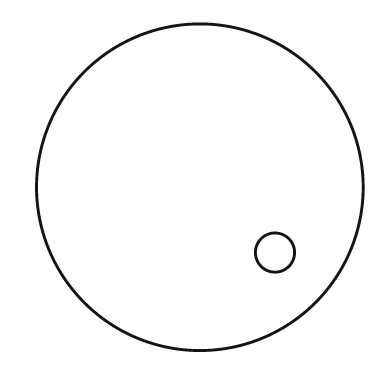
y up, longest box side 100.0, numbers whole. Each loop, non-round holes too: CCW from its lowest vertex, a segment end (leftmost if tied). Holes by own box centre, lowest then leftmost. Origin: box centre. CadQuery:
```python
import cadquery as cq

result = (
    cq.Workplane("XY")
    .moveTo(0.0, 0.0)
    .circle(50.0)
    .moveTo(23.0, -20.0)
    .circle(6.0)
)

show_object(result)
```